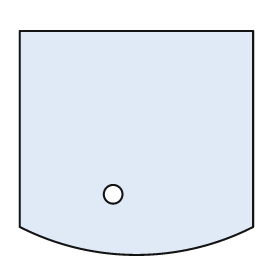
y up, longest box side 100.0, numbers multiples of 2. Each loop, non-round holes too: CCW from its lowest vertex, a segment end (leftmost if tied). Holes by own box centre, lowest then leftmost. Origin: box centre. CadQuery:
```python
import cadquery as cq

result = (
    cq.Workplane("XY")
    .moveTo(-50.0, -36.0)
    .threePointArc((0.0, -48.0), (50.0, -36.0))
    .lineTo(50.0, 48.0)
    .lineTo(-50.0, 48.0)
    .close()
    .moveTo(-10.0, -22.0)
    .circle(4.0)
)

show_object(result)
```